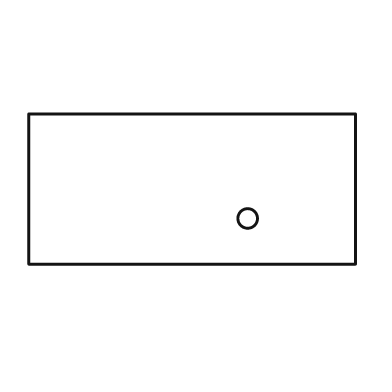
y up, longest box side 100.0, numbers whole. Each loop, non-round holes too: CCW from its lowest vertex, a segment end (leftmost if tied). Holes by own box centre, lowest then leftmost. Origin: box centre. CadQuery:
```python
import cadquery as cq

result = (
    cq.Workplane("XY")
    .moveTo(-50.0, -23.0)
    .lineTo(50.0, -23.0)
    .lineTo(50.0, 23.0)
    .lineTo(-50.0, 23.0)
    .close()
    .moveTo(17.0, -9.0)
    .circle(3.0)
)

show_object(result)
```